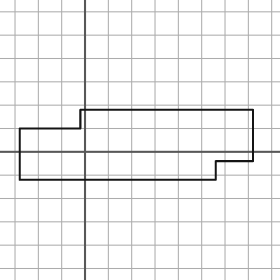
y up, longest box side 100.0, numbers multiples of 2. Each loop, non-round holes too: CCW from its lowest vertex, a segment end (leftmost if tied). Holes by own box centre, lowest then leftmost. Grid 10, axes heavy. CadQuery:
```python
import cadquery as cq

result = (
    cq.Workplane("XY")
    .moveTo(-28.0, -12.0)
    .lineTo(56.0, -12.0)
    .lineTo(56.0, -4.0)
    .lineTo(72.0, -4.0)
    .lineTo(72.0, 18.0)
    .lineTo(-2.0, 18.0)
    .lineTo(-2.0, 10.0)
    .lineTo(-28.0, 10.0)
    .close()
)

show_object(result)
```